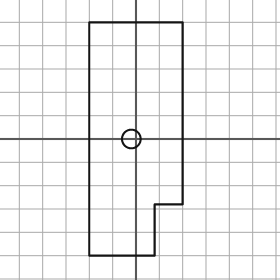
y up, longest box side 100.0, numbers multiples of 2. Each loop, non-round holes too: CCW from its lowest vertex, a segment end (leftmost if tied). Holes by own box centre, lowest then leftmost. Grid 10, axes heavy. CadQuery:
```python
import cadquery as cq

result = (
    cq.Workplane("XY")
    .moveTo(-20.0, -50.0)
    .lineTo(8.0, -50.0)
    .lineTo(8.0, -28.0)
    .lineTo(20.0, -28.0)
    .lineTo(20.0, 50.0)
    .lineTo(-20.0, 50.0)
    .close()
    .moveTo(-2.0, 0.0)
    .circle(4.0)
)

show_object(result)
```